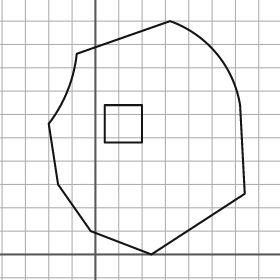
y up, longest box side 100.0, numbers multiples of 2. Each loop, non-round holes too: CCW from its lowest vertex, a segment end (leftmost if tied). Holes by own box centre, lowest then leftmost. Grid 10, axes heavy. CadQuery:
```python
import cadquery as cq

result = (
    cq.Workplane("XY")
    .moveTo(24.0, 0.0)
    .lineTo(64.0, 26.0)
    .lineTo(62.0, 64.0)
    .threePointArc((52.0, 86.0), (32.0, 100.0))
    .lineTo(-8.0, 86.0)
    .threePointArc((-12.0, 70.0), (-20.0, 56.0))
    .lineTo(-16.0, 30.0)
    .lineTo(-2.0, 10.0)
    .close()
    .moveTo(4.0, 48.0)
    .lineTo(20.0, 48.0)
    .lineTo(20.0, 64.0)
    .lineTo(4.0, 64.0)
    .close()
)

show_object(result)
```